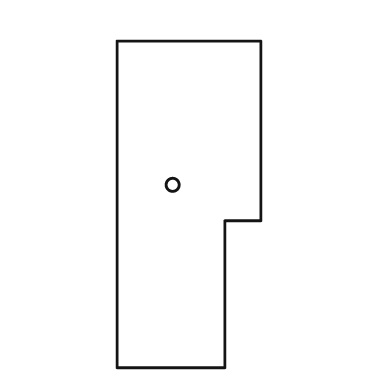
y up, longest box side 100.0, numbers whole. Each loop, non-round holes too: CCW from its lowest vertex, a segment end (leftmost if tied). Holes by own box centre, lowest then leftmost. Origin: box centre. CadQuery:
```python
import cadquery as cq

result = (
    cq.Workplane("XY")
    .moveTo(-22.0, -50.0)
    .lineTo(11.0, -50.0)
    .lineTo(11.0, -5.0)
    .lineTo(22.0, -5.0)
    .lineTo(22.0, 50.0)
    .lineTo(-22.0, 50.0)
    .close()
    .moveTo(-5.0, 6.0)
    .circle(2.0)
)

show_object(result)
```